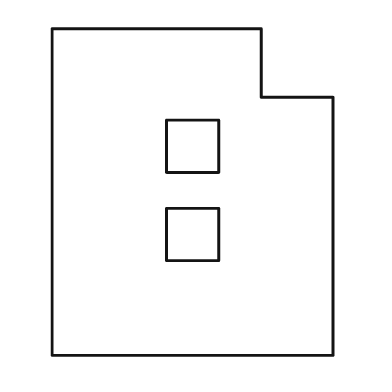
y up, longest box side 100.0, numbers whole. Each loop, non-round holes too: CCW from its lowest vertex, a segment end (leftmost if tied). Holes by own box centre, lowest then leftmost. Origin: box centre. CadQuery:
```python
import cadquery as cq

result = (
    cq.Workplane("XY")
    .moveTo(-43.0, -50.0)
    .lineTo(43.0, -50.0)
    .lineTo(43.0, 29.0)
    .lineTo(21.0, 29.0)
    .lineTo(21.0, 50.0)
    .lineTo(-43.0, 50.0)
    .close()
    .moveTo(-8.0, -21.0)
    .lineTo(8.0, -21.0)
    .lineTo(8.0, -5.0)
    .lineTo(-8.0, -5.0)
    .close()
    .moveTo(-8.0, 6.0)
    .lineTo(8.0, 6.0)
    .lineTo(8.0, 22.0)
    .lineTo(-8.0, 22.0)
    .close()
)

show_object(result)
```